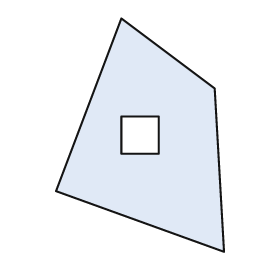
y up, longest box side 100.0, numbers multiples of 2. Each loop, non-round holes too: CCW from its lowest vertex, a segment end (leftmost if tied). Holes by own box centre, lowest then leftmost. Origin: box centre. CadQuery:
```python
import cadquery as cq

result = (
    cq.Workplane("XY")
    .moveTo(36.0, -50.0)
    .lineTo(32.0, 20.0)
    .lineTo(-8.0, 50.0)
    .lineTo(-36.0, -24.0)
    .close()
    .moveTo(-8.0, -8.0)
    .lineTo(8.0, -8.0)
    .lineTo(8.0, 8.0)
    .lineTo(-8.0, 8.0)
    .close()
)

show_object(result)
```